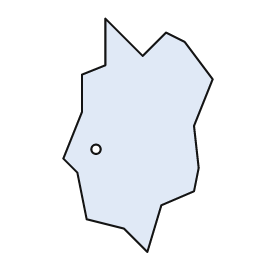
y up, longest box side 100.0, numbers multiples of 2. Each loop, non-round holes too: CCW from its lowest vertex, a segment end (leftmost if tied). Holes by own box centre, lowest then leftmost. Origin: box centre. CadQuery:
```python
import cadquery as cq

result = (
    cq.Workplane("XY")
    .moveTo(4.0, -50.0)
    .lineTo(10.0, -30.0)
    .lineTo(24.0, -24.0)
    .lineTo(26.0, -14.0)
    .lineTo(24.0, 4.0)
    .lineTo(32.0, 24.0)
    .lineTo(20.0, 40.0)
    .lineTo(12.0, 44.0)
    .lineTo(2.0, 34.0)
    .lineTo(-14.0, 50.0)
    .lineTo(-14.0, 30.0)
    .lineTo(-24.0, 26.0)
    .lineTo(-24.0, 10.0)
    .lineTo(-32.0, -10.0)
    .lineTo(-26.0, -16.0)
    .lineTo(-22.0, -36.0)
    .lineTo(-6.0, -40.0)
    .close()
    .moveTo(-18.0, -6.0)
    .circle(2.0)
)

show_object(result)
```